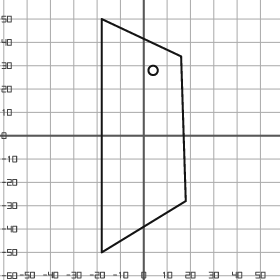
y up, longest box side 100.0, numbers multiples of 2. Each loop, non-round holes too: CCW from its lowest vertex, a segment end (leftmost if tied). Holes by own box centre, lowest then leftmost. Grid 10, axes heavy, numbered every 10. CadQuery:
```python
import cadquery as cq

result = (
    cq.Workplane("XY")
    .moveTo(-18.0, -50.0)
    .lineTo(18.0, -28.0)
    .lineTo(16.0, 34.0)
    .lineTo(-18.0, 50.0)
    .close()
    .moveTo(4.0, 28.0)
    .circle(2.0)
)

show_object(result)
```